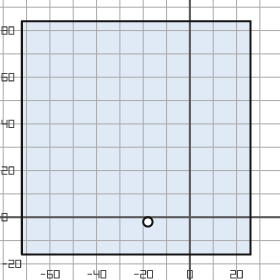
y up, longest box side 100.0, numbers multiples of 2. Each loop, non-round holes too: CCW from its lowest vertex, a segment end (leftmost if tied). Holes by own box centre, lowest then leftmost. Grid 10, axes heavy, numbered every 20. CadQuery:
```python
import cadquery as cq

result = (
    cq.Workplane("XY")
    .moveTo(-72.0, -16.0)
    .lineTo(26.0, -16.0)
    .lineTo(26.0, 84.0)
    .lineTo(-72.0, 84.0)
    .close()
    .moveTo(-18.0, -2.0)
    .circle(2.0)
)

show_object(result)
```